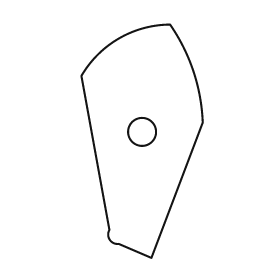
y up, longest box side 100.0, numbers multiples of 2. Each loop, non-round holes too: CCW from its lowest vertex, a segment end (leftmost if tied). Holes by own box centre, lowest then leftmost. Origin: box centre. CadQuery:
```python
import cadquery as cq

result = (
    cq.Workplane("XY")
    .moveTo(4.0, -50.0)
    .lineTo(26.0, 8.0)
    .threePointArc((22.0, 30.0), (12.0, 50.0))
    .threePointArc((-10.0, 44.0), (-26.0, 28.0))
    .lineTo(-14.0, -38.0)
    .threePointArc((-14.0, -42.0), (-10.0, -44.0))
    .close()
    .moveTo(0.0, 4.0)
    .circle(6.0)
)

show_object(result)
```